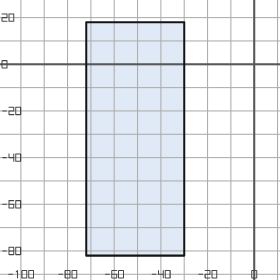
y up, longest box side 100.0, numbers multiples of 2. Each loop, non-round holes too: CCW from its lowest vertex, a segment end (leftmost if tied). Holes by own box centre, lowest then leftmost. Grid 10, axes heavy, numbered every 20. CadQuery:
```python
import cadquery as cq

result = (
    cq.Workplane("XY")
    .moveTo(-72.0, -82.0)
    .lineTo(-30.0, -82.0)
    .lineTo(-30.0, 18.0)
    .lineTo(-72.0, 18.0)
    .close()
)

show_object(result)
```